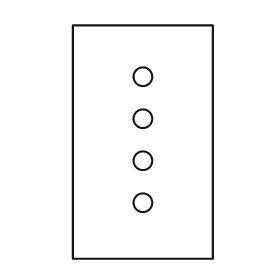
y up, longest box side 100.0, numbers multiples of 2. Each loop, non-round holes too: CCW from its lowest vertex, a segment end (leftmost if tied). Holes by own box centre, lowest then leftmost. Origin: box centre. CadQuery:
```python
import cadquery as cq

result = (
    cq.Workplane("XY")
    .moveTo(-30.0, -50.0)
    .lineTo(30.0, -50.0)
    .lineTo(30.0, 50.0)
    .lineTo(-30.0, 50.0)
    .close()
    .moveTo(0.0, -26.0)
    .circle(4.0)
    .moveTo(0.0, -8.0)
    .circle(4.0)
    .moveTo(0.0, 10.0)
    .circle(4.0)
    .moveTo(0.0, 28.0)
    .circle(4.0)
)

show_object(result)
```